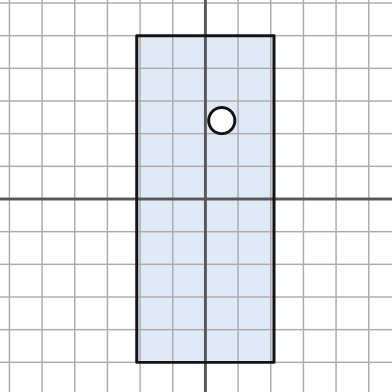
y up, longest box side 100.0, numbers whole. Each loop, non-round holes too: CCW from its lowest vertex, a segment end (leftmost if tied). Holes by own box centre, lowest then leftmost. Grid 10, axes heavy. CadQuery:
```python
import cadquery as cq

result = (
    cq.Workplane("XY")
    .moveTo(-21.0, -50.0)
    .lineTo(21.0, -50.0)
    .lineTo(21.0, 50.0)
    .lineTo(-21.0, 50.0)
    .close()
    .moveTo(5.0, 24.0)
    .circle(4.0)
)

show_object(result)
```